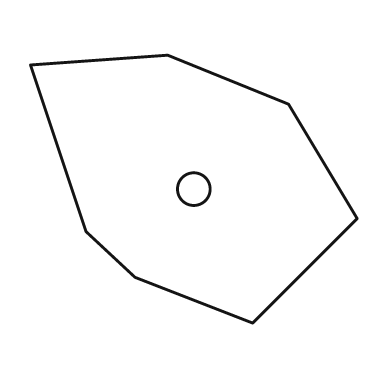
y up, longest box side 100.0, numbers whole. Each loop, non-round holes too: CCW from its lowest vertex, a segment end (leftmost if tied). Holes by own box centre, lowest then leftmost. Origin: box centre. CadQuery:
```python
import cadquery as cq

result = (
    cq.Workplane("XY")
    .moveTo(18.0, -41.0)
    .lineTo(50.0, -9.0)
    .lineTo(29.0, 26.0)
    .lineTo(-8.0, 41.0)
    .lineTo(-50.0, 38.0)
    .lineTo(-33.0, -13.0)
    .lineTo(-18.0, -27.0)
    .close()
    .moveTo(0.0, 0.0)
    .circle(5.0)
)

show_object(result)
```